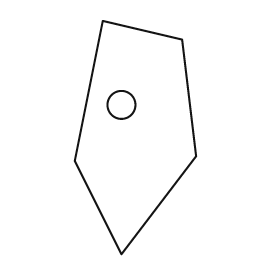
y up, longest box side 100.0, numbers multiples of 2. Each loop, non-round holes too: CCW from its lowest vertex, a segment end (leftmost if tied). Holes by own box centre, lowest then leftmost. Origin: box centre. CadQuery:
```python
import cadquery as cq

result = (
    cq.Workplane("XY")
    .moveTo(-6.0, -50.0)
    .lineTo(26.0, -8.0)
    .lineTo(20.0, 42.0)
    .lineTo(-14.0, 50.0)
    .lineTo(-26.0, -10.0)
    .close()
    .moveTo(-6.0, 14.0)
    .circle(6.0)
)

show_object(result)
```